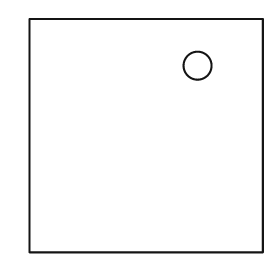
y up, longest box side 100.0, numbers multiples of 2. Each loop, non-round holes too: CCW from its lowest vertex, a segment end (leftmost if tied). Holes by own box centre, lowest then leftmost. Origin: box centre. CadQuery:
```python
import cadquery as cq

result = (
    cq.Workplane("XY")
    .moveTo(-50.0, -50.0)
    .lineTo(50.0, -50.0)
    .lineTo(50.0, 50.0)
    .lineTo(-50.0, 50.0)
    .close()
    .moveTo(22.0, 30.0)
    .circle(6.0)
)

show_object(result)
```